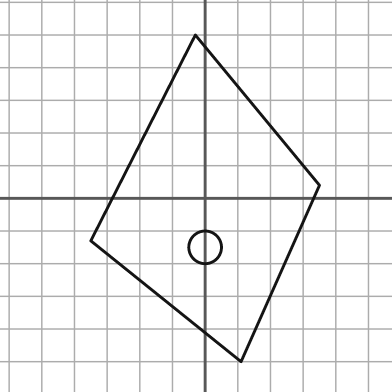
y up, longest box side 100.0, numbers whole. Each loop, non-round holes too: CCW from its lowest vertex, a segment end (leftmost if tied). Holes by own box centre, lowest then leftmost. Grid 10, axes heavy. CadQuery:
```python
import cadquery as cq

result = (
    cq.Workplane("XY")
    .moveTo(11.0, -50.0)
    .lineTo(35.0, 4.0)
    .lineTo(-3.0, 50.0)
    .lineTo(-35.0, -13.0)
    .close()
    .moveTo(0.0, -15.0)
    .circle(5.0)
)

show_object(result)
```